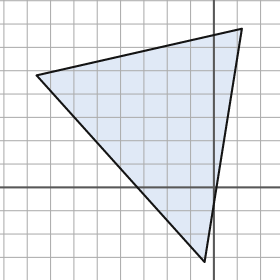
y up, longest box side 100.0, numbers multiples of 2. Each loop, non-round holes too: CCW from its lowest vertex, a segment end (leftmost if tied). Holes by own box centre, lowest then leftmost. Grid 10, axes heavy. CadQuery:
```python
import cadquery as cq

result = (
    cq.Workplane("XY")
    .moveTo(-4.0, -32.0)
    .lineTo(12.0, 68.0)
    .lineTo(-76.0, 48.0)
    .close()
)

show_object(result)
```